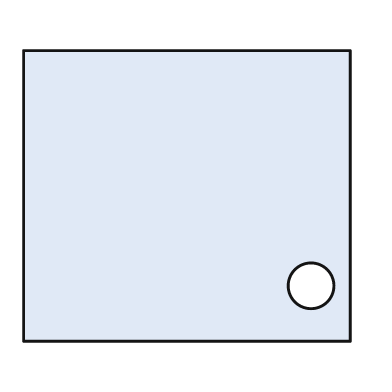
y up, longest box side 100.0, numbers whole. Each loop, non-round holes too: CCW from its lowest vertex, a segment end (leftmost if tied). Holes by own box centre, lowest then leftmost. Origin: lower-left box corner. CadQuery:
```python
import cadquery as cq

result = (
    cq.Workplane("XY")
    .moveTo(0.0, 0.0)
    .lineTo(100.0, 0.0)
    .lineTo(100.0, 89.0)
    .lineTo(0.0, 89.0)
    .close()
    .moveTo(88.0, 17.0)
    .circle(7.0)
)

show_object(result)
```